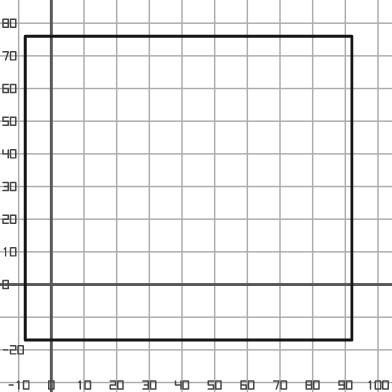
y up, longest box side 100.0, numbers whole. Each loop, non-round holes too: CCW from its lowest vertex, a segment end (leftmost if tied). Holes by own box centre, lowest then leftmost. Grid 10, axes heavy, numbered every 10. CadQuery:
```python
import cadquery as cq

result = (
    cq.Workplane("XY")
    .moveTo(-8.0, -17.0)
    .lineTo(92.0, -17.0)
    .lineTo(92.0, 76.0)
    .lineTo(-8.0, 76.0)
    .close()
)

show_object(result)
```